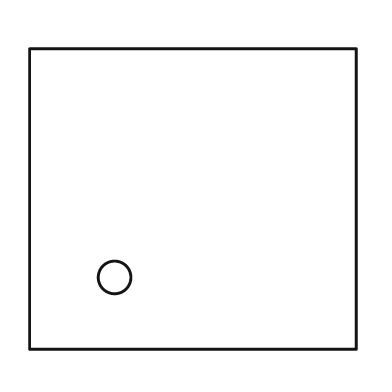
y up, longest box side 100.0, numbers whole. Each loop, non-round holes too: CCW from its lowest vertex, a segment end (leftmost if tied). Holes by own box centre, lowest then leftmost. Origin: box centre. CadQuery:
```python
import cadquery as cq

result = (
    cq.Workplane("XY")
    .moveTo(-50.0, -46.0)
    .lineTo(50.0, -46.0)
    .lineTo(50.0, 46.0)
    .lineTo(-50.0, 46.0)
    .close()
    .moveTo(-24.0, -24.0)
    .circle(5.0)
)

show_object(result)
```